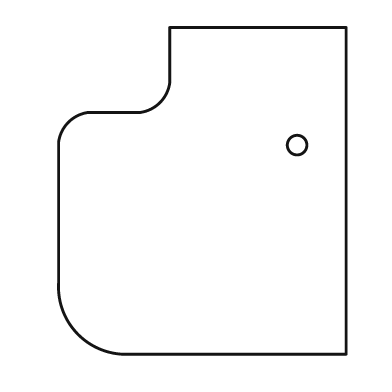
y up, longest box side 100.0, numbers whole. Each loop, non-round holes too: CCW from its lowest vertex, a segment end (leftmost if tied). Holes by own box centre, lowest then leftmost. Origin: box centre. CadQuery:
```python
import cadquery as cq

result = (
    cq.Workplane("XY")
    .moveTo(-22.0, -50.0)
    .lineTo(44.0, -50.0)
    .lineTo(44.0, 50.0)
    .lineTo(-10.0, 50.0)
    .lineTo(-10.0, 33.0)
    .threePointArc((-13.0, 27.0), (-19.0, 24.0))
    .lineTo(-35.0, 24.0)
    .threePointArc((-41.0, 21.0), (-44.0, 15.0))
    .lineTo(-44.0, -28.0)
    .threePointArc((-38.0, -44.0), (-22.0, -50.0))
    .close()
    .moveTo(29.0, 14.0)
    .circle(3.0)
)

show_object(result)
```